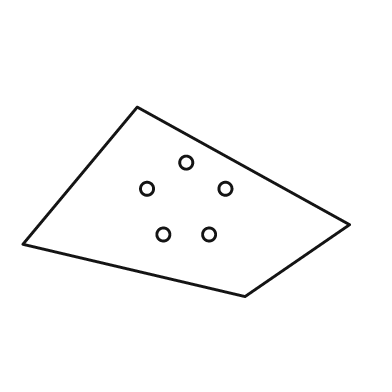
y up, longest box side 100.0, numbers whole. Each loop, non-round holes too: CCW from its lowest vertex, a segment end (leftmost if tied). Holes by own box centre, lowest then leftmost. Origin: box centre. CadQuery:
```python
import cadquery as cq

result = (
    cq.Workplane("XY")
    .moveTo(18.0, -29.0)
    .lineTo(50.0, -7.0)
    .lineTo(-15.0, 29.0)
    .lineTo(-50.0, -13.0)
    .close()
    .moveTo(-7.0, -10.0)
    .circle(2.0)
    .moveTo(7.0, -10.0)
    .circle(2.0)
    .moveTo(-12.0, 4.0)
    .circle(2.0)
    .moveTo(12.0, 4.0)
    .circle(2.0)
    .moveTo(0.0, 12.0)
    .circle(2.0)
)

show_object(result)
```